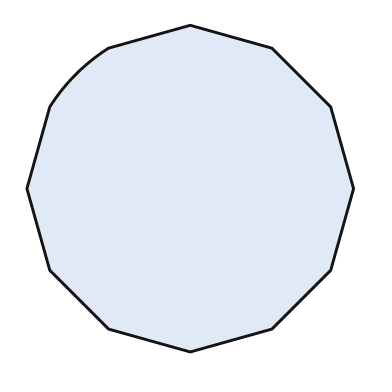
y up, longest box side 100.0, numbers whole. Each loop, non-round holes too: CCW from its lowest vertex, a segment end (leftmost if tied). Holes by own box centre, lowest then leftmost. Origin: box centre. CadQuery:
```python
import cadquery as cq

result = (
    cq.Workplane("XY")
    .moveTo(0.0, -50.0)
    .lineTo(25.0, -43.0)
    .lineTo(43.0, -25.0)
    .lineTo(50.0, 0.0)
    .lineTo(43.0, 25.0)
    .lineTo(25.0, 43.0)
    .lineTo(0.0, 50.0)
    .lineTo(-25.0, 43.0)
    .threePointArc((-35.0, 35.0), (-43.0, 25.0))
    .lineTo(-50.0, 0.0)
    .lineTo(-43.0, -25.0)
    .lineTo(-25.0, -43.0)
    .close()
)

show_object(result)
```